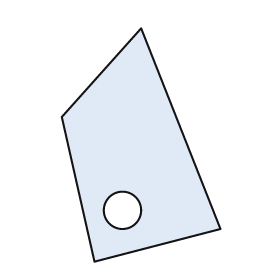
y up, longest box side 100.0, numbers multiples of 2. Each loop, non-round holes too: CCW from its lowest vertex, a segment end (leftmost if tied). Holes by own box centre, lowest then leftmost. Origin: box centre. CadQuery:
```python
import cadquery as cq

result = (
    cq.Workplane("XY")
    .moveTo(-20.0, -50.0)
    .lineTo(34.0, -36.0)
    .lineTo(0.0, 50.0)
    .lineTo(-34.0, 12.0)
    .close()
    .moveTo(-8.0, -28.0)
    .circle(8.0)
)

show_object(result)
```